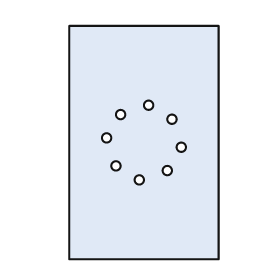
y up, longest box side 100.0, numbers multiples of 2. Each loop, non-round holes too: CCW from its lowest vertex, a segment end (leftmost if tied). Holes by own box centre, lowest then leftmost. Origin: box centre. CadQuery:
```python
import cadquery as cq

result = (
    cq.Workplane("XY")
    .moveTo(-32.0, -50.0)
    .lineTo(32.0, -50.0)
    .lineTo(32.0, 50.0)
    .lineTo(-32.0, 50.0)
    .close()
    .moveTo(-2.0, -16.0)
    .circle(2.0)
    .moveTo(10.0, -12.0)
    .circle(2.0)
    .moveTo(-12.0, -10.0)
    .circle(2.0)
    .moveTo(16.0, -2.0)
    .circle(2.0)
    .moveTo(-16.0, 2.0)
    .circle(2.0)
    .moveTo(12.0, 10.0)
    .circle(2.0)
    .moveTo(-10.0, 12.0)
    .circle(2.0)
    .moveTo(2.0, 16.0)
    .circle(2.0)
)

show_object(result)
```